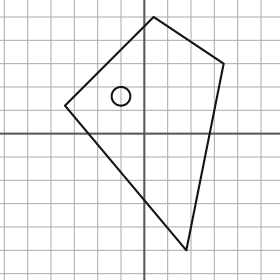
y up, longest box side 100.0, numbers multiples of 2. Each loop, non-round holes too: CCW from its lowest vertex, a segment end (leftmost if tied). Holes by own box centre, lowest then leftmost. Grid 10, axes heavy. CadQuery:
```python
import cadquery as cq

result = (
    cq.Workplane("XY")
    .moveTo(18.0, -50.0)
    .lineTo(34.0, 30.0)
    .lineTo(4.0, 50.0)
    .lineTo(-34.0, 12.0)
    .close()
    .moveTo(-10.0, 16.0)
    .circle(4.0)
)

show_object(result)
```